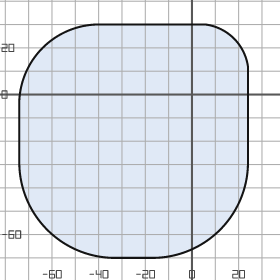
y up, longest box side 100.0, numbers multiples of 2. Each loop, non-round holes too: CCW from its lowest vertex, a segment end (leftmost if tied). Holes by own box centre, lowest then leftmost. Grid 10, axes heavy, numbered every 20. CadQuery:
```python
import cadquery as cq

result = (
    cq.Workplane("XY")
    .moveTo(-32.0, -70.0)
    .lineTo(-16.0, -70.0)
    .threePointArc((12.0, -58.0), (24.0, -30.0))
    .lineTo(24.0, 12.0)
    .threePointArc((18.0, 24.0), (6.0, 30.0))
    .lineTo(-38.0, 30.0)
    .threePointArc((-64.0, 20.0), (-74.0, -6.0))
    .lineTo(-74.0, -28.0)
    .threePointArc((-62.0, -58.0), (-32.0, -70.0))
    .close()
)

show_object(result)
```